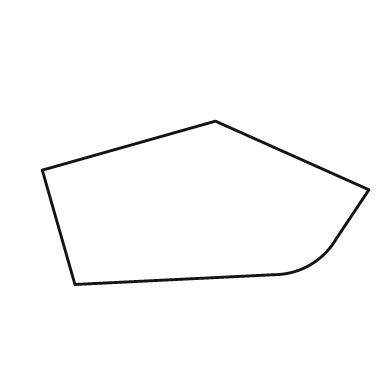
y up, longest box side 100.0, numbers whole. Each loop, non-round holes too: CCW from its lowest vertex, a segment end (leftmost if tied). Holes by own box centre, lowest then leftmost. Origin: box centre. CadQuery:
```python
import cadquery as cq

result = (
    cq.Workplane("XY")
    .moveTo(-40.0, -25.0)
    .lineTo(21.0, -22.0)
    .threePointArc((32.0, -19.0), (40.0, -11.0))
    .lineTo(50.0, 4.0)
    .lineTo(3.0, 25.0)
    .lineTo(-50.0, 10.0)
    .close()
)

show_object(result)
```